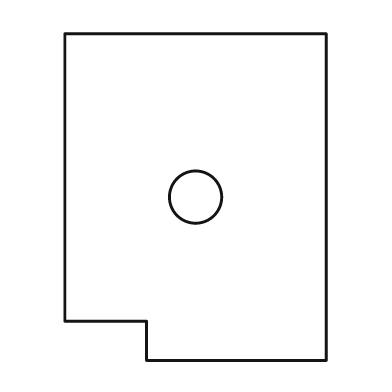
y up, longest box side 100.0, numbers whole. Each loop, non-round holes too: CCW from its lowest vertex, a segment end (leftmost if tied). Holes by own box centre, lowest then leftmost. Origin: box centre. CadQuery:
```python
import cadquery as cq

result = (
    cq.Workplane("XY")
    .moveTo(-15.0, -50.0)
    .lineTo(40.0, -50.0)
    .lineTo(40.0, 50.0)
    .lineTo(-40.0, 50.0)
    .lineTo(-40.0, -38.0)
    .lineTo(-15.0, -38.0)
    .close()
    .moveTo(0.0, 0.0)
    .circle(8.0)
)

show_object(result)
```